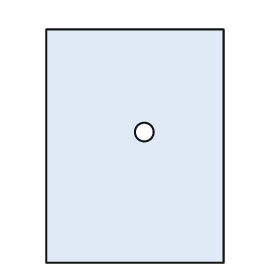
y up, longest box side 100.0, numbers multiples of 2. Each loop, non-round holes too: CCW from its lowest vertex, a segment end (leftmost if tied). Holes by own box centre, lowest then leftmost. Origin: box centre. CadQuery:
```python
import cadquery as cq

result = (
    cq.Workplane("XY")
    .moveTo(-38.0, -50.0)
    .lineTo(38.0, -50.0)
    .lineTo(38.0, 50.0)
    .lineTo(-38.0, 50.0)
    .close()
    .moveTo(4.0, 6.0)
    .circle(4.0)
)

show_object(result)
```